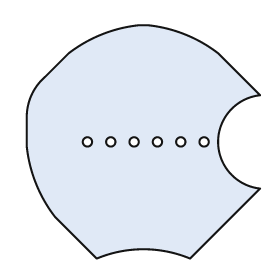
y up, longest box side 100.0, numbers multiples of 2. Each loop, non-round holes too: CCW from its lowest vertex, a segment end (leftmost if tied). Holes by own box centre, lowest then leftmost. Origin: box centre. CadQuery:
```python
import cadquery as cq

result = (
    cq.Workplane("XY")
    .moveTo(-20.0, -50.0)
    .threePointArc((0.0, -46.0), (20.0, -50.0))
    .lineTo(50.0, -20.0)
    .threePointArc((32.0, 0.0), (50.0, 20.0))
    .lineTo(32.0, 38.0)
    .threePointArc((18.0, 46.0), (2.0, 50.0))
    .lineTo(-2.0, 50.0)
    .threePointArc((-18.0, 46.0), (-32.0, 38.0))
    .lineTo(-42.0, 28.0)
    .threePointArc((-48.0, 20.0), (-50.0, 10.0))
    .lineTo(-50.0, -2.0)
    .threePointArc((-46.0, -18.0), (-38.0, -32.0))
    .close()
    .moveTo(-24.0, 0.0)
    .circle(2.0)
    .moveTo(-14.0, 0.0)
    .circle(2.0)
    .moveTo(-4.0, 0.0)
    .circle(2.0)
    .moveTo(6.0, 0.0)
    .circle(2.0)
    .moveTo(16.0, 0.0)
    .circle(2.0)
    .moveTo(26.0, 0.0)
    .circle(2.0)
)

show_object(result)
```